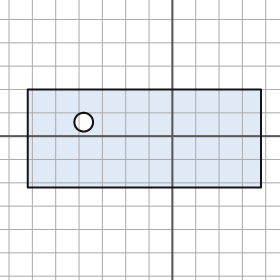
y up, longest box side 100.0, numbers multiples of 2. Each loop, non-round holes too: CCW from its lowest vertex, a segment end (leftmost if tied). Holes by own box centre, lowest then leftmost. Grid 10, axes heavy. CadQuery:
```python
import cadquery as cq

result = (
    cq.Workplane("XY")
    .moveTo(-62.0, -22.0)
    .lineTo(38.0, -22.0)
    .lineTo(38.0, 20.0)
    .lineTo(-62.0, 20.0)
    .close()
    .moveTo(-38.0, 6.0)
    .circle(4.0)
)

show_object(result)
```